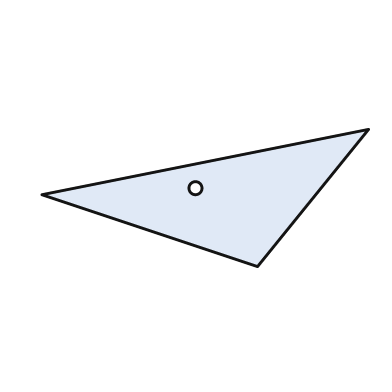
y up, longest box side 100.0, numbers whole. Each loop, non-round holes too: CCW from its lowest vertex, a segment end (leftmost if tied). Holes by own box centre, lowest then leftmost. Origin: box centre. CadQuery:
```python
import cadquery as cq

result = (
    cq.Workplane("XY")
    .moveTo(16.0, -21.0)
    .lineTo(50.0, 21.0)
    .lineTo(-50.0, 1.0)
    .close()
    .moveTo(-3.0, 3.0)
    .circle(2.0)
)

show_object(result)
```